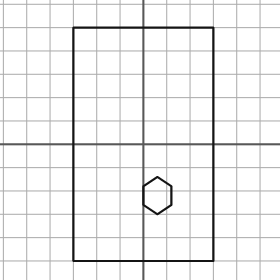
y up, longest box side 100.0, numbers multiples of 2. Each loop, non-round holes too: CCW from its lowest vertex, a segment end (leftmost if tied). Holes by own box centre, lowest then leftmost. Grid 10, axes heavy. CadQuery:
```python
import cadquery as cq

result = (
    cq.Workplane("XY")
    .moveTo(-30.0, -50.0)
    .lineTo(30.0, -50.0)
    .lineTo(30.0, 50.0)
    .lineTo(-30.0, 50.0)
    .close()
    .moveTo(6.0, -30.0)
    .lineTo(12.0, -26.0)
    .lineTo(12.0, -18.0)
    .lineTo(6.0, -14.0)
    .lineTo(0.0, -18.0)
    .lineTo(0.0, -26.0)
    .close()
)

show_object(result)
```